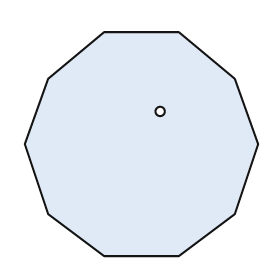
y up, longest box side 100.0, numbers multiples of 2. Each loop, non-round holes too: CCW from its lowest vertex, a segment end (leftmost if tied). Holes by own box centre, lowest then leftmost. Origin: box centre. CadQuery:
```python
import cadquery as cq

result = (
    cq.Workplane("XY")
    .moveTo(-16.0, -48.0)
    .lineTo(16.0, -48.0)
    .lineTo(40.0, -30.0)
    .lineTo(50.0, 0.0)
    .lineTo(40.0, 28.0)
    .lineTo(16.0, 48.0)
    .lineTo(-16.0, 48.0)
    .lineTo(-40.0, 28.0)
    .lineTo(-50.0, 0.0)
    .lineTo(-40.0, -30.0)
    .close()
    .moveTo(8.0, 14.0)
    .circle(2.0)
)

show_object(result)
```